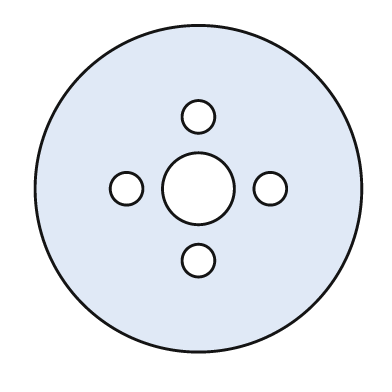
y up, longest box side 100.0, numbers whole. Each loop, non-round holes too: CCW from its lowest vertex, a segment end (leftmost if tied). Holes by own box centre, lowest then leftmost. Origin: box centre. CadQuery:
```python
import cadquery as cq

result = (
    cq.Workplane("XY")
    .moveTo(0.0, 0.0)
    .circle(50.0)
    .moveTo(0.0, -22.0)
    .circle(5.0)
    .moveTo(-22.0, 0.0)
    .circle(5.0)
    .moveTo(0.0, 0.0)
    .circle(11.0)
    .moveTo(22.0, 0.0)
    .circle(5.0)
    .moveTo(0.0, 22.0)
    .circle(5.0)
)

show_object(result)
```